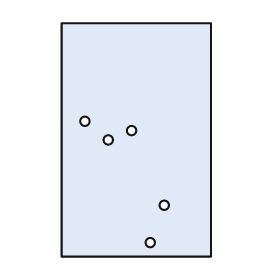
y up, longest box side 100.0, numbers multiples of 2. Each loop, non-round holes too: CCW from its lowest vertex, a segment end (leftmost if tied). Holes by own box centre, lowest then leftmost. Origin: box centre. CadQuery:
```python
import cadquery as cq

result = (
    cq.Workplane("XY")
    .moveTo(-32.0, -50.0)
    .lineTo(32.0, -50.0)
    .lineTo(32.0, 50.0)
    .lineTo(-32.0, 50.0)
    .close()
    .moveTo(6.0, -44.0)
    .circle(2.0)
    .moveTo(12.0, -28.0)
    .circle(2.0)
    .moveTo(-12.0, 0.0)
    .circle(2.0)
    .moveTo(-2.0, 4.0)
    .circle(2.0)
    .moveTo(-22.0, 8.0)
    .circle(2.0)
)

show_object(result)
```